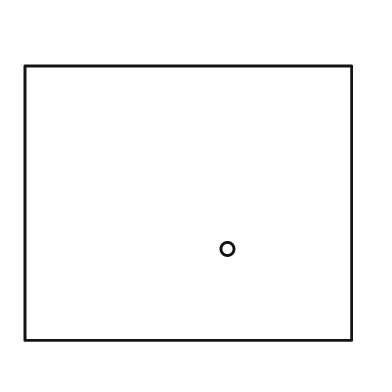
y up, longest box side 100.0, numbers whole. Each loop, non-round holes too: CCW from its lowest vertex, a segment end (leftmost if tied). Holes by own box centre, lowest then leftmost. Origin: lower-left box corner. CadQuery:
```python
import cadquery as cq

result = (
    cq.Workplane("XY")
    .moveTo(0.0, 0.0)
    .lineTo(100.0, 0.0)
    .lineTo(100.0, 84.0)
    .lineTo(0.0, 84.0)
    .close()
    .moveTo(62.0, 28.0)
    .circle(2.0)
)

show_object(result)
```